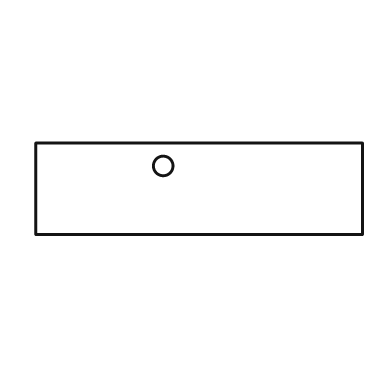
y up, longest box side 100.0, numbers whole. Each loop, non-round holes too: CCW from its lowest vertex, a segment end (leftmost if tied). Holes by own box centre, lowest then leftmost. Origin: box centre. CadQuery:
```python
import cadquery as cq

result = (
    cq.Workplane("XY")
    .moveTo(-50.0, -14.0)
    .lineTo(50.0, -14.0)
    .lineTo(50.0, 14.0)
    .lineTo(-50.0, 14.0)
    .close()
    .moveTo(-11.0, 7.0)
    .circle(3.0)
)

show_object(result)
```